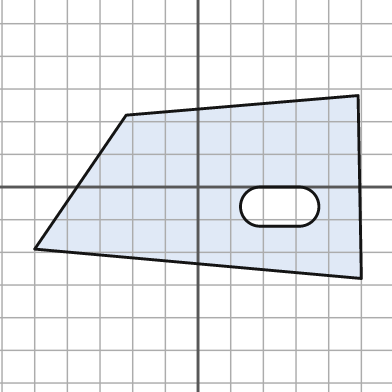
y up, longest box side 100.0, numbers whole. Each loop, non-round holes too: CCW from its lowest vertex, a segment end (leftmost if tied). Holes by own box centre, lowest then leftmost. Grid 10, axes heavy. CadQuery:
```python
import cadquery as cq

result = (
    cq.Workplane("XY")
    .moveTo(50.0, -28.0)
    .lineTo(49.0, 28.0)
    .lineTo(-22.0, 22.0)
    .lineTo(-50.0, -19.0)
    .close()
    .moveTo(19.0, -12.0)
    .lineTo(31.0, -12.0)
    .threePointArc((37.0, -6.0), (31.0, 0.0))
    .lineTo(19.0, 0.0)
    .threePointArc((13.0, -6.0), (19.0, -12.0))
    .close()
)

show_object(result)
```